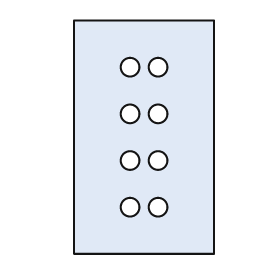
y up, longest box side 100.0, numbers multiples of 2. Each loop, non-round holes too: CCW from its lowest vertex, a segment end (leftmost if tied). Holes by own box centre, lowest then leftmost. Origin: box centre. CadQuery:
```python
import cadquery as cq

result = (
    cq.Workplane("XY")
    .moveTo(-30.0, -50.0)
    .lineTo(30.0, -50.0)
    .lineTo(30.0, 50.0)
    .lineTo(-30.0, 50.0)
    .close()
    .moveTo(-6.0, -30.0)
    .circle(4.0)
    .moveTo(6.0, -30.0)
    .circle(4.0)
    .moveTo(-6.0, -10.0)
    .circle(4.0)
    .moveTo(6.0, -10.0)
    .circle(4.0)
    .moveTo(-6.0, 10.0)
    .circle(4.0)
    .moveTo(6.0, 10.0)
    .circle(4.0)
    .moveTo(-6.0, 30.0)
    .circle(4.0)
    .moveTo(6.0, 30.0)
    .circle(4.0)
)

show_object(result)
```